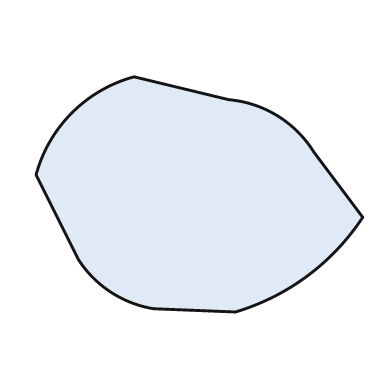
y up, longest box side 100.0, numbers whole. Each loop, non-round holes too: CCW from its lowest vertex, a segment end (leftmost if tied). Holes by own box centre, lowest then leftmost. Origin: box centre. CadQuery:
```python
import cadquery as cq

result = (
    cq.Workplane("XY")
    .moveTo(11.0, -36.0)
    .threePointArc((33.0, -25.0), (50.0, -7.0))
    .lineTo(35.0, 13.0)
    .threePointArc((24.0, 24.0), (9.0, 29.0))
    .lineTo(-20.0, 36.0)
    .threePointArc((-39.0, 25.0), (-50.0, 6.0))
    .lineTo(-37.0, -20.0)
    .threePointArc((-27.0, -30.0), (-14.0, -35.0))
    .close()
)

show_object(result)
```